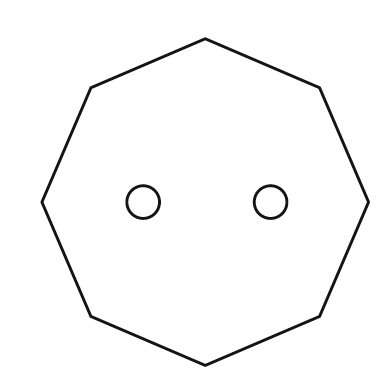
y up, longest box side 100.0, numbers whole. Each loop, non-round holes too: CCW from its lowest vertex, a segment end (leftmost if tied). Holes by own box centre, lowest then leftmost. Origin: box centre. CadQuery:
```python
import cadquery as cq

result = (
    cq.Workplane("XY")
    .moveTo(0.0, -50.0)
    .lineTo(35.0, -35.0)
    .lineTo(50.0, 0.0)
    .lineTo(35.0, 35.0)
    .lineTo(0.0, 50.0)
    .lineTo(-35.0, 35.0)
    .lineTo(-50.0, 0.0)
    .lineTo(-35.0, -35.0)
    .close()
    .moveTo(-19.0, 0.0)
    .circle(5.0)
    .moveTo(20.0, 0.0)
    .circle(5.0)
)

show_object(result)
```